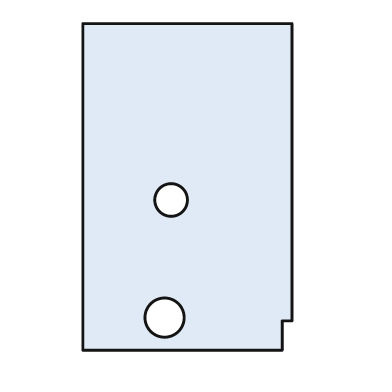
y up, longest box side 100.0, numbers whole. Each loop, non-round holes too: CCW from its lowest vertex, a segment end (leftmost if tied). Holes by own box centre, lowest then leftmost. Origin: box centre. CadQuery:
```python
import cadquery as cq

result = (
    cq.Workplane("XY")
    .moveTo(-32.0, -50.0)
    .lineTo(29.0, -50.0)
    .lineTo(29.0, -41.0)
    .lineTo(32.0, -41.0)
    .lineTo(32.0, 50.0)
    .lineTo(-32.0, 50.0)
    .close()
    .moveTo(-7.0, -40.0)
    .circle(6.0)
    .moveTo(-5.0, -4.0)
    .circle(5.0)
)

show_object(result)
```